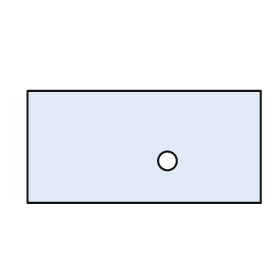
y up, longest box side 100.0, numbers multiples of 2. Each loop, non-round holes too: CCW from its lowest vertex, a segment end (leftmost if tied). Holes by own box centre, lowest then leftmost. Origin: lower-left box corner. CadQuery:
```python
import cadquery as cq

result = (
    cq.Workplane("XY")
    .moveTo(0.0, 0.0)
    .lineTo(100.0, 0.0)
    .lineTo(100.0, 48.0)
    .lineTo(0.0, 48.0)
    .close()
    .moveTo(60.0, 18.0)
    .circle(4.0)
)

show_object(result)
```